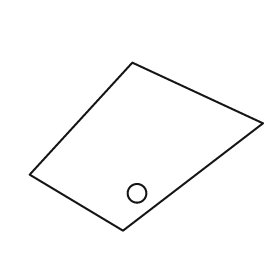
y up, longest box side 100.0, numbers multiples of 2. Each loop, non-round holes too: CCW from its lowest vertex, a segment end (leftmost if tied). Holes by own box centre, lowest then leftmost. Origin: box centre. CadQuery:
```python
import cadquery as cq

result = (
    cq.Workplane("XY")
    .moveTo(-10.0, -36.0)
    .lineTo(50.0, 10.0)
    .lineTo(-6.0, 36.0)
    .lineTo(-50.0, -12.0)
    .close()
    .moveTo(-4.0, -20.0)
    .circle(4.0)
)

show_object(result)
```